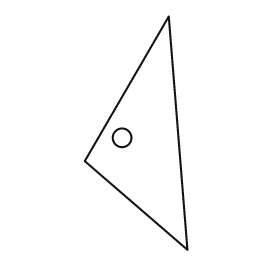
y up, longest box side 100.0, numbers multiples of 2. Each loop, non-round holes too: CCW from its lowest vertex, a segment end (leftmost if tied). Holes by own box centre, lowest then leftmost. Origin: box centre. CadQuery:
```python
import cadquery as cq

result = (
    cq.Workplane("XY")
    .moveTo(22.0, -50.0)
    .lineTo(14.0, 50.0)
    .lineTo(-22.0, -12.0)
    .close()
    .moveTo(-6.0, -2.0)
    .circle(4.0)
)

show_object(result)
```